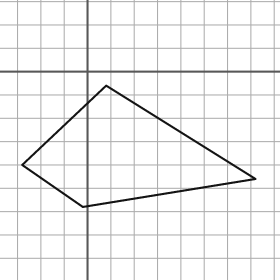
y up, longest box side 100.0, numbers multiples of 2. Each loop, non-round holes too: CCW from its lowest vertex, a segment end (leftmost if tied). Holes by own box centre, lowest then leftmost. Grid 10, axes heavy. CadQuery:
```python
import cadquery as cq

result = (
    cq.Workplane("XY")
    .moveTo(-2.0, -58.0)
    .lineTo(72.0, -46.0)
    .lineTo(8.0, -6.0)
    .lineTo(-28.0, -40.0)
    .close()
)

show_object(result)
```